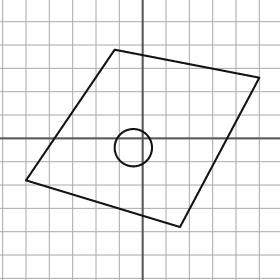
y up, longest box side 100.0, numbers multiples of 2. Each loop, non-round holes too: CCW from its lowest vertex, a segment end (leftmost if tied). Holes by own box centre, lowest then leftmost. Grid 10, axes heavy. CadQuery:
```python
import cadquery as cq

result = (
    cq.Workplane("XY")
    .moveTo(16.0, -38.0)
    .lineTo(50.0, 26.0)
    .lineTo(-12.0, 38.0)
    .lineTo(-50.0, -18.0)
    .close()
    .moveTo(-4.0, -4.0)
    .circle(8.0)
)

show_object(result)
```